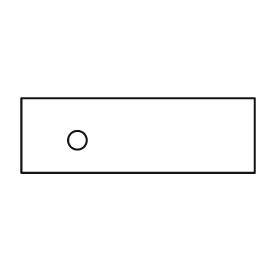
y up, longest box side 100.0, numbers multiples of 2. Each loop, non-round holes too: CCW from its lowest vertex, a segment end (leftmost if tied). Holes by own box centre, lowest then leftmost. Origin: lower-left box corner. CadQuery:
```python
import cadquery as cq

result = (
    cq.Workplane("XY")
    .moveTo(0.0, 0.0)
    .lineTo(100.0, 0.0)
    .lineTo(100.0, 32.0)
    .lineTo(0.0, 32.0)
    .close()
    .moveTo(24.0, 14.0)
    .circle(4.0)
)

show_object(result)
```